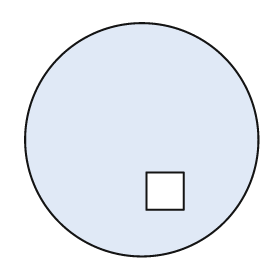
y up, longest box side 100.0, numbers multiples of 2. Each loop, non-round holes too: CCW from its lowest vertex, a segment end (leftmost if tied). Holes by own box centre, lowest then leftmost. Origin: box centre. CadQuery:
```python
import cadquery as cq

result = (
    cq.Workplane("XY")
    .moveTo(0.0, 0.0)
    .circle(50.0)
    .moveTo(2.0, -30.0)
    .lineTo(18.0, -30.0)
    .lineTo(18.0, -14.0)
    .lineTo(2.0, -14.0)
    .close()
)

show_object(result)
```